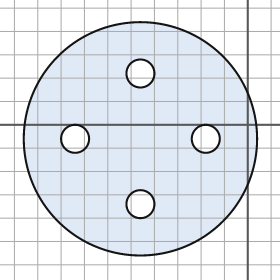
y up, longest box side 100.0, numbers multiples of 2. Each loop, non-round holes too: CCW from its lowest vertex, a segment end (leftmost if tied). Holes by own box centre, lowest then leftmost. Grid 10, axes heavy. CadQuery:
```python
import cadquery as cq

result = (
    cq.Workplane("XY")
    .moveTo(-46.0, -6.0)
    .circle(50.0)
    .moveTo(-46.0, -34.0)
    .circle(6.0)
    .moveTo(-74.0, -6.0)
    .circle(6.0)
    .moveTo(-18.0, -6.0)
    .circle(6.0)
    .moveTo(-46.0, 22.0)
    .circle(6.0)
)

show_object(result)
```